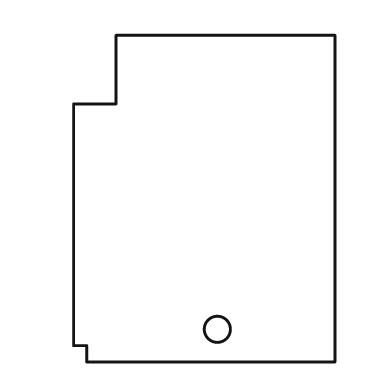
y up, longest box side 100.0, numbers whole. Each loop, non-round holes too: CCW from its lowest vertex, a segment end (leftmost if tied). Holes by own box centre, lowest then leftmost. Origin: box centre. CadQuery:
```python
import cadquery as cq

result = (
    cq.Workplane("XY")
    .moveTo(-36.0, -50.0)
    .lineTo(40.0, -50.0)
    .lineTo(40.0, 50.0)
    .lineTo(-27.0, 50.0)
    .lineTo(-27.0, 29.0)
    .lineTo(-40.0, 29.0)
    .lineTo(-40.0, -45.0)
    .lineTo(-36.0, -45.0)
    .close()
    .moveTo(4.0, -40.0)
    .circle(4.0)
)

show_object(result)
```